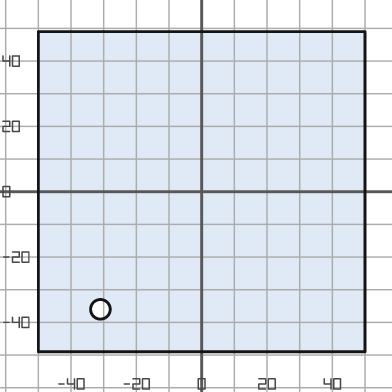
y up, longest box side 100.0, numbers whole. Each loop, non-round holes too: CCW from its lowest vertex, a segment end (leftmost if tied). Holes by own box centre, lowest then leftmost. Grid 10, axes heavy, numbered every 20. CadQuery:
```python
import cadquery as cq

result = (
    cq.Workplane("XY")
    .moveTo(-50.0, -49.0)
    .lineTo(50.0, -49.0)
    .lineTo(50.0, 49.0)
    .lineTo(-50.0, 49.0)
    .close()
    .moveTo(-31.0, -36.0)
    .circle(3.0)
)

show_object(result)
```